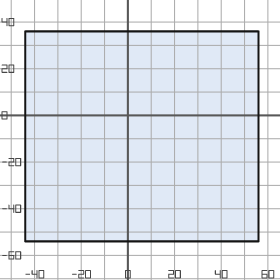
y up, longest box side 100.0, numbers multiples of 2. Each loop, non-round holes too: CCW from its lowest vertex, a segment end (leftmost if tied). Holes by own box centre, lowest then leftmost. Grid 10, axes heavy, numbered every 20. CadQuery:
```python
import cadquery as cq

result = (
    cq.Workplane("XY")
    .moveTo(-44.0, -54.0)
    .lineTo(56.0, -54.0)
    .lineTo(56.0, 36.0)
    .lineTo(-44.0, 36.0)
    .close()
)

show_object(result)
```